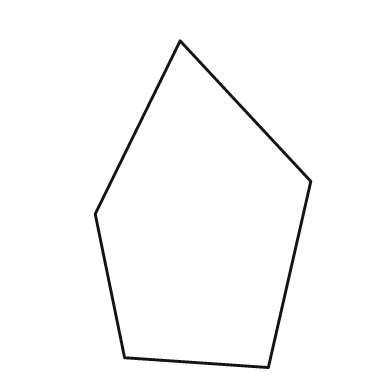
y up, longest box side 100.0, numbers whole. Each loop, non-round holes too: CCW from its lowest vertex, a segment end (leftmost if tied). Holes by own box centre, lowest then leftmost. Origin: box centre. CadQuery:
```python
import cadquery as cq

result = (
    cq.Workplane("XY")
    .moveTo(20.0, -50.0)
    .lineTo(33.0, 7.0)
    .lineTo(-7.0, 50.0)
    .lineTo(-33.0, -3.0)
    .lineTo(-24.0, -47.0)
    .close()
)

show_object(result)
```